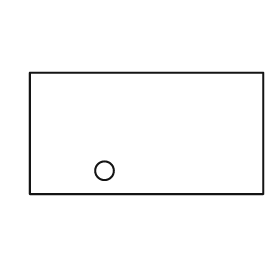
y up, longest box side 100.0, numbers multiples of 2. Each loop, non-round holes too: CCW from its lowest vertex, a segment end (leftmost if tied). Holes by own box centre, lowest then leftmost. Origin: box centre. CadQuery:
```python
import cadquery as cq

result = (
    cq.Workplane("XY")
    .moveTo(-50.0, -26.0)
    .lineTo(50.0, -26.0)
    .lineTo(50.0, 26.0)
    .lineTo(-50.0, 26.0)
    .close()
    .moveTo(-18.0, -16.0)
    .circle(4.0)
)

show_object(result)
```